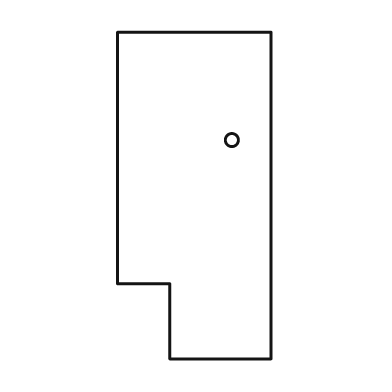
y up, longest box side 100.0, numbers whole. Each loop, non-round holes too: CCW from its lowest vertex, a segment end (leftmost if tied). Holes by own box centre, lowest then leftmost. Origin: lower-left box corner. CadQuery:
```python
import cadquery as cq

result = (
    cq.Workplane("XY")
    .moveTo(16.0, 0.0)
    .lineTo(47.0, 0.0)
    .lineTo(47.0, 100.0)
    .lineTo(0.0, 100.0)
    .lineTo(0.0, 23.0)
    .lineTo(16.0, 23.0)
    .close()
    .moveTo(35.0, 67.0)
    .circle(2.0)
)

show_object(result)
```